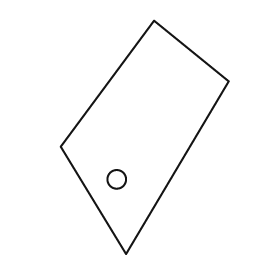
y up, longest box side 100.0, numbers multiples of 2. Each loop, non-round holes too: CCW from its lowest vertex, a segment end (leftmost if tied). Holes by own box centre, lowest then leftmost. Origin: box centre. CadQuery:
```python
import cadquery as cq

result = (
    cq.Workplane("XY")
    .moveTo(-8.0, -50.0)
    .lineTo(36.0, 24.0)
    .lineTo(4.0, 50.0)
    .lineTo(-36.0, -4.0)
    .close()
    .moveTo(-12.0, -18.0)
    .circle(4.0)
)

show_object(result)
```